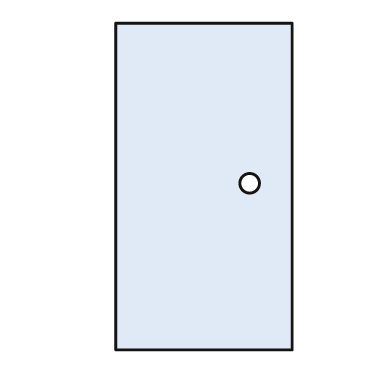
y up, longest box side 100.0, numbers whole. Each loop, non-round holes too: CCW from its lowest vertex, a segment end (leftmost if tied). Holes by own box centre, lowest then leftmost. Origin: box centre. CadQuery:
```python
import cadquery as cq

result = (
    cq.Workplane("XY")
    .moveTo(-27.0, -50.0)
    .lineTo(27.0, -50.0)
    .lineTo(27.0, 50.0)
    .lineTo(-27.0, 50.0)
    .close()
    .moveTo(14.0, 1.0)
    .circle(3.0)
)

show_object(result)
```